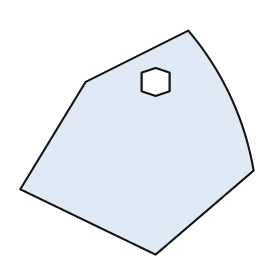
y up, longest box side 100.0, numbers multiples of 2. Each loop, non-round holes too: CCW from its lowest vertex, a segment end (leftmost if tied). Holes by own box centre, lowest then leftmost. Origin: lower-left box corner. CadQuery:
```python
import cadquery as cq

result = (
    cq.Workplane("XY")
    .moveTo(58.0, 0.0)
    .lineTo(100.0, 36.0)
    .threePointArc((90.0, 68.0), (72.0, 96.0))
    .lineTo(28.0, 74.0)
    .lineTo(0.0, 28.0)
    .close()
    .moveTo(58.0, 68.0)
    .lineTo(64.0, 70.0)
    .lineTo(64.0, 78.0)
    .lineTo(58.0, 80.0)
    .lineTo(52.0, 78.0)
    .lineTo(52.0, 70.0)
    .close()
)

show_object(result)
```